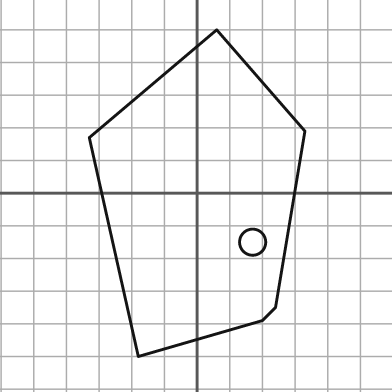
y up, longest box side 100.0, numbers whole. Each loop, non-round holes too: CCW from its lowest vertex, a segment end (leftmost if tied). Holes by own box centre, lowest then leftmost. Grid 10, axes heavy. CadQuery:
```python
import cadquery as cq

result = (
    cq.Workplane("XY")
    .moveTo(-18.0, -50.0)
    .lineTo(20.0, -39.0)
    .lineTo(24.0, -35.0)
    .lineTo(33.0, 19.0)
    .lineTo(6.0, 50.0)
    .lineTo(-33.0, 17.0)
    .close()
    .moveTo(17.0, -15.0)
    .circle(4.0)
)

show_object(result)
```